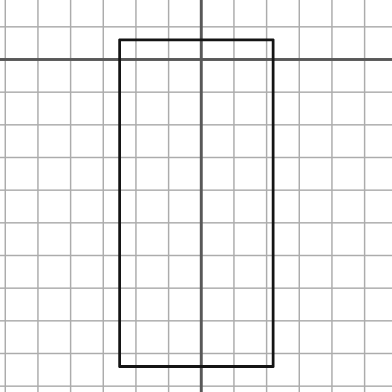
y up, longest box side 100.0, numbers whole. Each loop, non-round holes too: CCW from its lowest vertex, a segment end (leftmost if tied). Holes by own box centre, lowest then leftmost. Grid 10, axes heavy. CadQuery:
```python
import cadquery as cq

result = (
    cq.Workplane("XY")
    .moveTo(-25.0, -94.0)
    .lineTo(22.0, -94.0)
    .lineTo(22.0, 6.0)
    .lineTo(-25.0, 6.0)
    .close()
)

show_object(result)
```